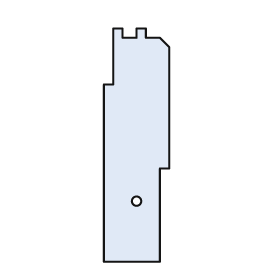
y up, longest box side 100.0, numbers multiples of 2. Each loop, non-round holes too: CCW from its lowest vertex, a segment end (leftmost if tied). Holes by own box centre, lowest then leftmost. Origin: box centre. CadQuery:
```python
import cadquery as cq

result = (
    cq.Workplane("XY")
    .moveTo(-14.0, -50.0)
    .lineTo(10.0, -50.0)
    .lineTo(10.0, -10.0)
    .lineTo(14.0, -10.0)
    .lineTo(14.0, 42.0)
    .lineTo(10.0, 46.0)
    .lineTo(4.0, 46.0)
    .lineTo(4.0, 50.0)
    .lineTo(0.0, 50.0)
    .lineTo(0.0, 46.0)
    .lineTo(-6.0, 46.0)
    .lineTo(-6.0, 50.0)
    .lineTo(-10.0, 50.0)
    .lineTo(-10.0, 26.0)
    .lineTo(-14.0, 26.0)
    .close()
    .moveTo(0.0, -24.0)
    .circle(2.0)
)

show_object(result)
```